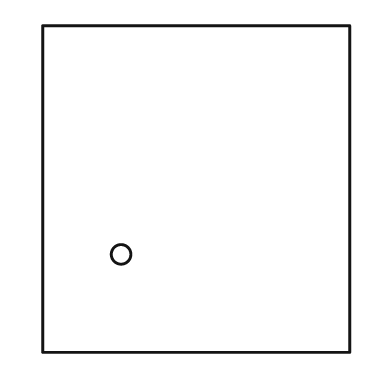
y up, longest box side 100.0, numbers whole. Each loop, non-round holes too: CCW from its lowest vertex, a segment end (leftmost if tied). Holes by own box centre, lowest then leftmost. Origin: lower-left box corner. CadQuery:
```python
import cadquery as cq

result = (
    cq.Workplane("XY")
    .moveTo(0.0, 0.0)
    .lineTo(94.0, 0.0)
    .lineTo(94.0, 100.0)
    .lineTo(0.0, 100.0)
    .close()
    .moveTo(24.0, 30.0)
    .circle(3.0)
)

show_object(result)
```